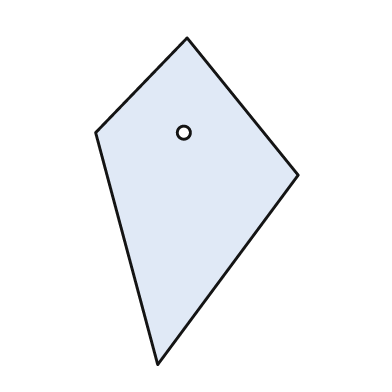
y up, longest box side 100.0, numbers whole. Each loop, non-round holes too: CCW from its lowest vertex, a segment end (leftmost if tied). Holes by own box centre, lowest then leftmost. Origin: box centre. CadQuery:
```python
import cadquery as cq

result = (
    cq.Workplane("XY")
    .moveTo(-12.0, -50.0)
    .lineTo(31.0, 8.0)
    .lineTo(-3.0, 50.0)
    .lineTo(-31.0, 21.0)
    .close()
    .moveTo(-4.0, 21.0)
    .circle(2.0)
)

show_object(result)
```